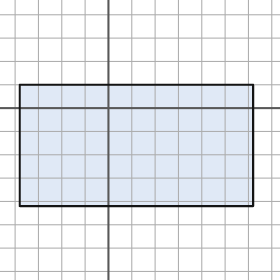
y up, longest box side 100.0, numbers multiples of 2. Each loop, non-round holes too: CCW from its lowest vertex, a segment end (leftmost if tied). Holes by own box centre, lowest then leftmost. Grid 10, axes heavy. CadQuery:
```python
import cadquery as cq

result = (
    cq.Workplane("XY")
    .moveTo(-38.0, -42.0)
    .lineTo(62.0, -42.0)
    .lineTo(62.0, 10.0)
    .lineTo(-38.0, 10.0)
    .close()
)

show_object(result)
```